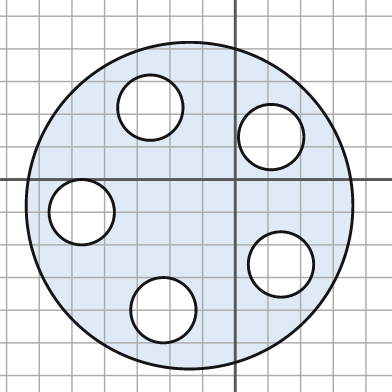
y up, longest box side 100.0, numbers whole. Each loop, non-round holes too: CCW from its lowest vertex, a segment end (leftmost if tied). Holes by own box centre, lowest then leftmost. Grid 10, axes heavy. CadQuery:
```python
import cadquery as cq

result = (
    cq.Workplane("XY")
    .moveTo(-14.0, -8.0)
    .circle(50.0)
    .moveTo(-22.0, -40.0)
    .circle(10.0)
    .moveTo(14.0, -26.0)
    .circle(10.0)
    .moveTo(-47.0, -10.0)
    .circle(10.0)
    .moveTo(11.0, 13.0)
    .circle(10.0)
    .moveTo(-26.0, 22.0)
    .circle(10.0)
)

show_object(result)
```